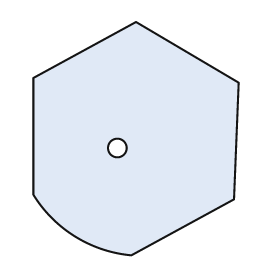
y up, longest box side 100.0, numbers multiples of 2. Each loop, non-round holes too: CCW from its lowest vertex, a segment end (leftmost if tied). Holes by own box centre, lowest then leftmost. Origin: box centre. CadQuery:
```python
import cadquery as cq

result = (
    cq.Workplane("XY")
    .moveTo(-2.0, -50.0)
    .lineTo(42.0, -26.0)
    .lineTo(44.0, 24.0)
    .lineTo(0.0, 50.0)
    .lineTo(-44.0, 26.0)
    .lineTo(-44.0, -24.0)
    .threePointArc((-26.0, -42.0), (-2.0, -50.0))
    .close()
    .moveTo(-8.0, -4.0)
    .circle(4.0)
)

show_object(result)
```